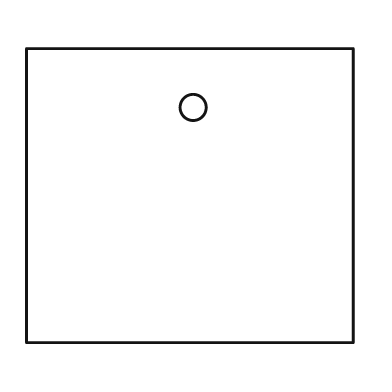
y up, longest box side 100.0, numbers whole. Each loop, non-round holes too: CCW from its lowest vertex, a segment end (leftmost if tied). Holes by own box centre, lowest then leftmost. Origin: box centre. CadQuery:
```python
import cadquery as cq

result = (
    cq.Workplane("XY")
    .moveTo(-50.0, -45.0)
    .lineTo(50.0, -45.0)
    .lineTo(50.0, 45.0)
    .lineTo(-50.0, 45.0)
    .close()
    .moveTo(1.0, 27.0)
    .circle(4.0)
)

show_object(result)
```